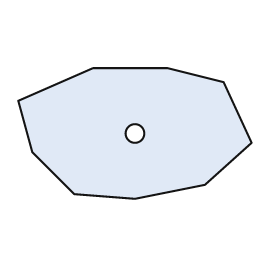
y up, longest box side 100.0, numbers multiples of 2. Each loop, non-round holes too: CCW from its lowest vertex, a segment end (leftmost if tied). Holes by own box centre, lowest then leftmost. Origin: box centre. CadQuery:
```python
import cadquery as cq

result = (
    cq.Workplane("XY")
    .moveTo(0.0, -28.0)
    .lineTo(30.0, -22.0)
    .lineTo(50.0, -4.0)
    .lineTo(38.0, 22.0)
    .lineTo(14.0, 28.0)
    .lineTo(-18.0, 28.0)
    .lineTo(-50.0, 14.0)
    .lineTo(-44.0, -8.0)
    .lineTo(-26.0, -26.0)
    .close()
    .moveTo(0.0, 0.0)
    .circle(4.0)
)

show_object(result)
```